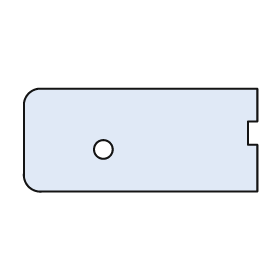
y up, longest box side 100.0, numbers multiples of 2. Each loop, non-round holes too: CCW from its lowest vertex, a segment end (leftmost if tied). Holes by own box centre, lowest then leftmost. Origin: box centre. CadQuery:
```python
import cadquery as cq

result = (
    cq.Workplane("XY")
    .moveTo(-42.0, -22.0)
    .lineTo(50.0, -22.0)
    .lineTo(50.0, -2.0)
    .lineTo(46.0, -2.0)
    .lineTo(46.0, 8.0)
    .lineTo(50.0, 8.0)
    .lineTo(50.0, 22.0)
    .lineTo(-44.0, 22.0)
    .threePointArc((-48.0, 20.0), (-50.0, 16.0))
    .lineTo(-50.0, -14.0)
    .threePointArc((-48.0, -20.0), (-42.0, -22.0))
    .close()
    .moveTo(-16.0, -4.0)
    .circle(4.0)
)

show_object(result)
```